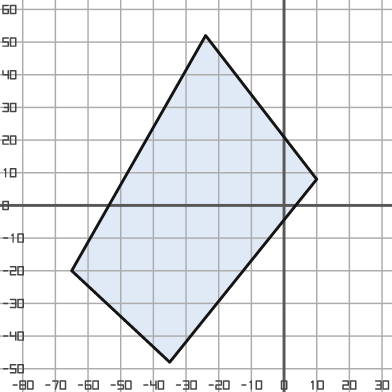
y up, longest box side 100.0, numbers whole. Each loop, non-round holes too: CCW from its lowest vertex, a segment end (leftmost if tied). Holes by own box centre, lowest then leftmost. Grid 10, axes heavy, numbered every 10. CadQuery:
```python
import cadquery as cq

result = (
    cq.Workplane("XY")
    .moveTo(-35.0, -48.0)
    .lineTo(10.0, 8.0)
    .lineTo(-24.0, 52.0)
    .lineTo(-65.0, -20.0)
    .close()
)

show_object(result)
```